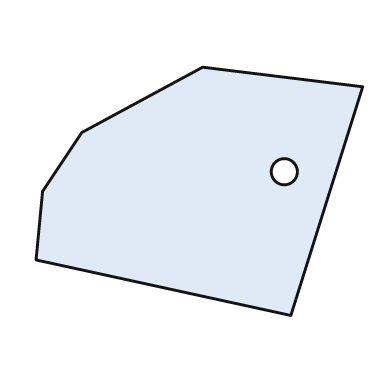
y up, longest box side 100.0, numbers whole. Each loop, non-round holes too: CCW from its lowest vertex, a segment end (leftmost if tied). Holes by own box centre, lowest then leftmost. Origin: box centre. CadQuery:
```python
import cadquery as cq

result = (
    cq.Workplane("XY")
    .moveTo(28.0, -38.0)
    .lineTo(50.0, 32.0)
    .lineTo(1.0, 38.0)
    .lineTo(-36.0, 18.0)
    .lineTo(-48.0, 0.0)
    .lineTo(-50.0, -21.0)
    .close()
    .moveTo(26.0, 6.0)
    .circle(4.0)
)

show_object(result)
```